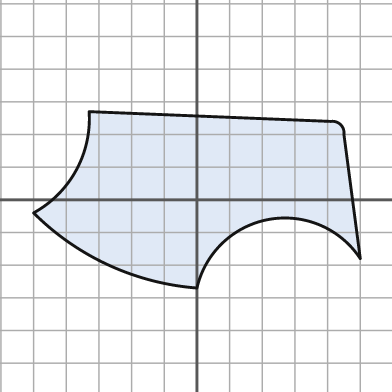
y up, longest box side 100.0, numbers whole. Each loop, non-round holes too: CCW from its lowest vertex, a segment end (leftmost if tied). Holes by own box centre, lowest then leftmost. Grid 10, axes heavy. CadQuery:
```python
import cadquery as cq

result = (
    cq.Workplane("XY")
    .moveTo(0.0, -27.0)
    .threePointArc((22.0, -6.0), (50.0, -18.0))
    .lineTo(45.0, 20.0)
    .threePointArc((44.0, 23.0), (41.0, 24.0))
    .lineTo(-33.0, 27.0)
    .threePointArc((-37.0, 9.0), (-50.0, -4.0))
    .threePointArc((-27.0, -20.0), (0.0, -27.0))
    .close()
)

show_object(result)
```